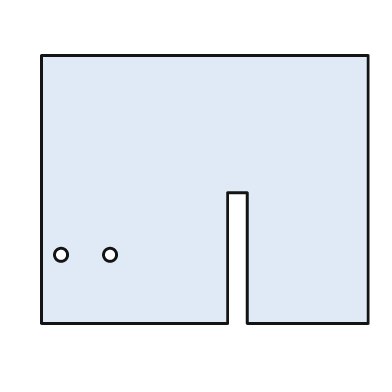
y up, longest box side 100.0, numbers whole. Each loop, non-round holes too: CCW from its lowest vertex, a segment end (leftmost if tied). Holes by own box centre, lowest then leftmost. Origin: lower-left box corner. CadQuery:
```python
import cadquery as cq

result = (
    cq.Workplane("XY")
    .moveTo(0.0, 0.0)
    .lineTo(57.0, 0.0)
    .lineTo(57.0, 40.0)
    .lineTo(63.0, 40.0)
    .lineTo(63.0, 0.0)
    .lineTo(100.0, 0.0)
    .lineTo(100.0, 82.0)
    .lineTo(0.0, 82.0)
    .close()
    .moveTo(6.0, 21.0)
    .circle(2.0)
    .moveTo(21.0, 21.0)
    .circle(2.0)
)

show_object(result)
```